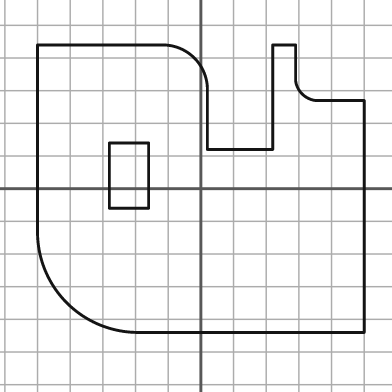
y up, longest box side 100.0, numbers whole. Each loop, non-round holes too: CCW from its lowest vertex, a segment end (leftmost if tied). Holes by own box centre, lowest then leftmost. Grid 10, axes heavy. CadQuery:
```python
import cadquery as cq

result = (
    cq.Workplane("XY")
    .moveTo(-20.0, -44.0)
    .lineTo(50.0, -44.0)
    .lineTo(50.0, 27.0)
    .lineTo(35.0, 27.0)
    .threePointArc((31.0, 29.0), (29.0, 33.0))
    .lineTo(29.0, 44.0)
    .lineTo(22.0, 44.0)
    .lineTo(22.0, 12.0)
    .lineTo(2.0, 12.0)
    .lineTo(2.0, 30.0)
    .threePointArc((-2.0, 40.0), (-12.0, 44.0))
    .lineTo(-50.0, 44.0)
    .lineTo(-50.0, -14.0)
    .threePointArc((-41.0, -35.0), (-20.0, -44.0))
    .close()
    .moveTo(-28.0, -6.0)
    .lineTo(-16.0, -6.0)
    .lineTo(-16.0, 14.0)
    .lineTo(-28.0, 14.0)
    .close()
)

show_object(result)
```